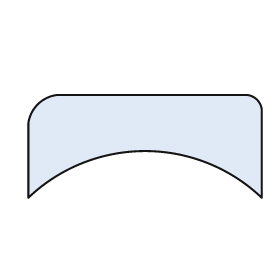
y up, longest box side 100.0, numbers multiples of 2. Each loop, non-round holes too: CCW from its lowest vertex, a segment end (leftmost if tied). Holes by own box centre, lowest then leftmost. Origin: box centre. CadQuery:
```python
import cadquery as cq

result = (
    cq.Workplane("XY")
    .moveTo(-50.0, -22.0)
    .threePointArc((0.0, -2.0), (50.0, -22.0))
    .lineTo(50.0, 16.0)
    .threePointArc((48.0, 20.0), (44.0, 22.0))
    .lineTo(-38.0, 22.0)
    .threePointArc((-46.0, 18.0), (-50.0, 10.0))
    .close()
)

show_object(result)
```